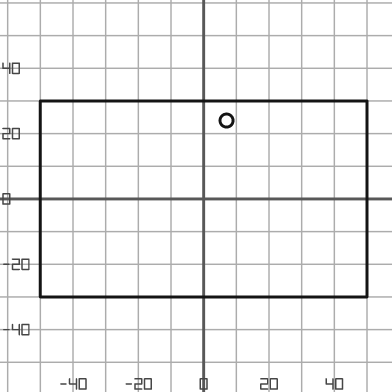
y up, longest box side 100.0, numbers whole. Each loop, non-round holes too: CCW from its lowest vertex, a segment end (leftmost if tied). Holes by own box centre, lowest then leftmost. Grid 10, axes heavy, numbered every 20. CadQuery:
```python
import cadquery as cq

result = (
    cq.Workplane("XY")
    .moveTo(-50.0, -30.0)
    .lineTo(50.0, -30.0)
    .lineTo(50.0, 30.0)
    .lineTo(-50.0, 30.0)
    .close()
    .moveTo(7.0, 24.0)
    .circle(2.0)
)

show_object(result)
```